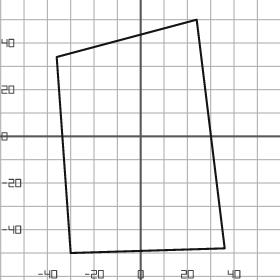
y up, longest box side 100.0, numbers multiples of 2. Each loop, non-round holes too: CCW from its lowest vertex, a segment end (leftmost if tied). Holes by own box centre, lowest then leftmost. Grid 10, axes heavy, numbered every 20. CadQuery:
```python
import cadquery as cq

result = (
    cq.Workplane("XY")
    .moveTo(-30.0, -50.0)
    .lineTo(36.0, -48.0)
    .lineTo(24.0, 50.0)
    .lineTo(-36.0, 34.0)
    .close()
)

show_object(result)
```